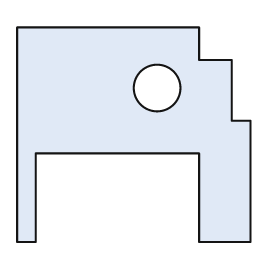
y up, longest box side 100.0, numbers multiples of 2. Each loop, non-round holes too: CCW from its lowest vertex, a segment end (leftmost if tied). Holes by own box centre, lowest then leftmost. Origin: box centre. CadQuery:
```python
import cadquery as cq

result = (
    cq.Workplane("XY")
    .moveTo(-50.0, -46.0)
    .lineTo(-42.0, -46.0)
    .lineTo(-42.0, -8.0)
    .lineTo(28.0, -8.0)
    .lineTo(28.0, -46.0)
    .lineTo(50.0, -46.0)
    .lineTo(50.0, 6.0)
    .lineTo(42.0, 6.0)
    .lineTo(42.0, 32.0)
    .lineTo(28.0, 32.0)
    .lineTo(28.0, 46.0)
    .lineTo(-50.0, 46.0)
    .close()
    .moveTo(10.0, 20.0)
    .circle(10.0)
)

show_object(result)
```